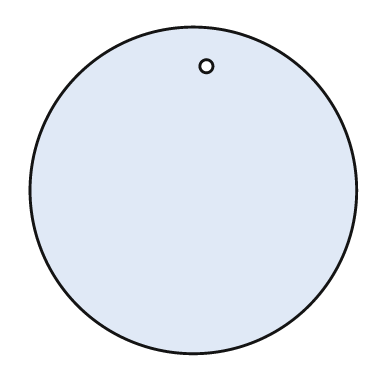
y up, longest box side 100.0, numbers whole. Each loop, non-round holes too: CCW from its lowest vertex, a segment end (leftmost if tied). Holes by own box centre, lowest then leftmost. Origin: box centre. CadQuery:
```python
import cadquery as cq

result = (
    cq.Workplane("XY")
    .moveTo(0.0, 0.0)
    .circle(50.0)
    .moveTo(4.0, 38.0)
    .circle(2.0)
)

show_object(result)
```